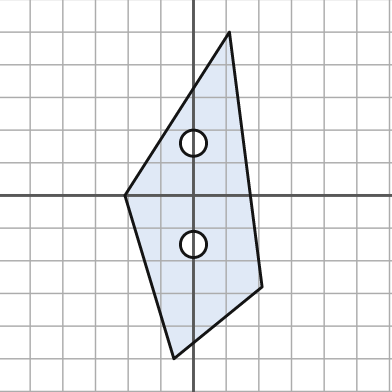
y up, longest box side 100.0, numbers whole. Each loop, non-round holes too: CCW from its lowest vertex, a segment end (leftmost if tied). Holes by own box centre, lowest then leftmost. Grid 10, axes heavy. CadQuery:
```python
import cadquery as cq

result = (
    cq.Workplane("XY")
    .moveTo(-6.0, -50.0)
    .lineTo(21.0, -28.0)
    .lineTo(11.0, 50.0)
    .lineTo(-21.0, 0.0)
    .close()
    .moveTo(0.0, -15.0)
    .circle(4.0)
    .moveTo(0.0, 16.0)
    .circle(4.0)
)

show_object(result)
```